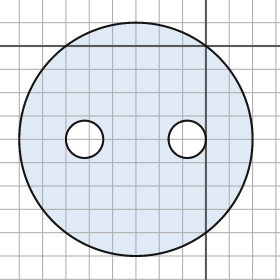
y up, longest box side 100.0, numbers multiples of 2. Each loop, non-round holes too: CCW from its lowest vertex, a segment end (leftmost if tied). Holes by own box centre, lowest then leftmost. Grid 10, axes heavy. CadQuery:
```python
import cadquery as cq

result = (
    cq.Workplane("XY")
    .moveTo(-30.0, -40.0)
    .circle(50.0)
    .moveTo(-52.0, -40.0)
    .circle(8.0)
    .moveTo(-8.0, -40.0)
    .circle(8.0)
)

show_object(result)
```